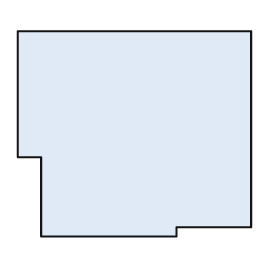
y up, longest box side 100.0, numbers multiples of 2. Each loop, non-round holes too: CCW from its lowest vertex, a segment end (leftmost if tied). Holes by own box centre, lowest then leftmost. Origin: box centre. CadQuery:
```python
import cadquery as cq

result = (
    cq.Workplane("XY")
    .moveTo(-40.0, -44.0)
    .lineTo(18.0, -44.0)
    .lineTo(18.0, -40.0)
    .lineTo(50.0, -40.0)
    .lineTo(50.0, 44.0)
    .lineTo(-50.0, 44.0)
    .lineTo(-50.0, -10.0)
    .lineTo(-40.0, -10.0)
    .close()
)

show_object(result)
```